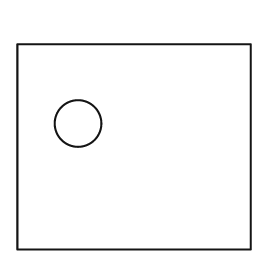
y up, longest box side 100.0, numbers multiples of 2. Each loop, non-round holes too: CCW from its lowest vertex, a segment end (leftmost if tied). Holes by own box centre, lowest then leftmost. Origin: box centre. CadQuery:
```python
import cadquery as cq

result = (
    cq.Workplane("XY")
    .moveTo(-50.0, -44.0)
    .lineTo(50.0, -44.0)
    .lineTo(50.0, 44.0)
    .lineTo(-50.0, 44.0)
    .close()
    .moveTo(-24.0, 10.0)
    .circle(10.0)
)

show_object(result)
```